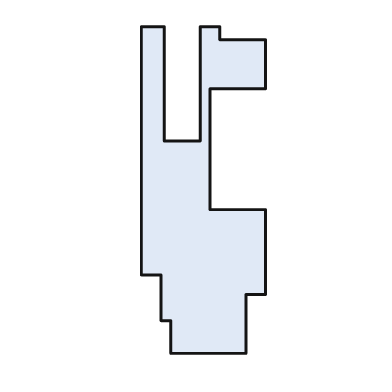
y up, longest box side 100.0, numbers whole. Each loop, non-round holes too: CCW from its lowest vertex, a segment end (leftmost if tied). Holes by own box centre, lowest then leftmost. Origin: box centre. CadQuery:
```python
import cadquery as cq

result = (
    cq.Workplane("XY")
    .moveTo(-10.0, -50.0)
    .lineTo(13.0, -50.0)
    .lineTo(13.0, -32.0)
    .lineTo(19.0, -32.0)
    .lineTo(19.0, -6.0)
    .lineTo(2.0, -6.0)
    .lineTo(2.0, 31.0)
    .lineTo(19.0, 31.0)
    .lineTo(19.0, 46.0)
    .lineTo(5.0, 46.0)
    .lineTo(5.0, 50.0)
    .lineTo(-1.0, 50.0)
    .lineTo(-1.0, 15.0)
    .lineTo(-12.0, 15.0)
    .lineTo(-12.0, 50.0)
    .lineTo(-19.0, 50.0)
    .lineTo(-19.0, -26.0)
    .lineTo(-13.0, -26.0)
    .lineTo(-13.0, -40.0)
    .lineTo(-10.0, -40.0)
    .close()
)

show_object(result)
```